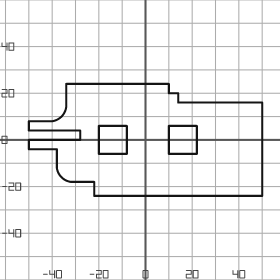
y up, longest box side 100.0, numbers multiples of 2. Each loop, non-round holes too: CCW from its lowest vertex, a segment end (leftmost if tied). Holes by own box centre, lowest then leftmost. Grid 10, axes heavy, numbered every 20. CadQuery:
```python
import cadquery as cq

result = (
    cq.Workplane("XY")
    .moveTo(-22.0, -24.0)
    .lineTo(50.0, -24.0)
    .lineTo(50.0, 16.0)
    .lineTo(14.0, 16.0)
    .lineTo(14.0, 20.0)
    .lineTo(10.0, 20.0)
    .lineTo(10.0, 24.0)
    .lineTo(-34.0, 24.0)
    .lineTo(-34.0, 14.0)
    .threePointArc((-36.0, 10.0), (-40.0, 8.0))
    .lineTo(-50.0, 8.0)
    .lineTo(-50.0, 4.0)
    .lineTo(-28.0, 4.0)
    .lineTo(-28.0, 0.0)
    .lineTo(-50.0, 0.0)
    .lineTo(-50.0, -4.0)
    .lineTo(-38.0, -4.0)
    .lineTo(-38.0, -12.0)
    .threePointArc((-36.0, -16.0), (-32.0, -18.0))
    .lineTo(-22.0, -18.0)
    .close()
    .moveTo(-20.0, -6.0)
    .lineTo(-8.0, -6.0)
    .lineTo(-8.0, 6.0)
    .lineTo(-20.0, 6.0)
    .close()
    .moveTo(10.0, -6.0)
    .lineTo(22.0, -6.0)
    .lineTo(22.0, 6.0)
    .lineTo(10.0, 6.0)
    .close()
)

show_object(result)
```